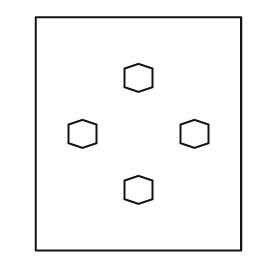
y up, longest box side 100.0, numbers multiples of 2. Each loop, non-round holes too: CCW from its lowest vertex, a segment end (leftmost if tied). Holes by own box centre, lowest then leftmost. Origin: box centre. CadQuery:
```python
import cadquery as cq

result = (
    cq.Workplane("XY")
    .moveTo(-44.0, -50.0)
    .lineTo(44.0, -50.0)
    .lineTo(44.0, 50.0)
    .lineTo(-44.0, 50.0)
    .close()
    .moveTo(0.0, -30.0)
    .lineTo(6.0, -28.0)
    .lineTo(6.0, -20.0)
    .lineTo(0.0, -18.0)
    .lineTo(-6.0, -20.0)
    .lineTo(-6.0, -28.0)
    .close()
    .moveTo(-24.0, -6.0)
    .lineTo(-18.0, -4.0)
    .lineTo(-18.0, 4.0)
    .lineTo(-24.0, 6.0)
    .lineTo(-30.0, 4.0)
    .lineTo(-30.0, -4.0)
    .close()
    .moveTo(24.0, -6.0)
    .lineTo(30.0, -4.0)
    .lineTo(30.0, 4.0)
    .lineTo(24.0, 6.0)
    .lineTo(18.0, 4.0)
    .lineTo(18.0, -4.0)
    .close()
    .moveTo(0.0, 18.0)
    .lineTo(6.0, 20.0)
    .lineTo(6.0, 28.0)
    .lineTo(0.0, 30.0)
    .lineTo(-6.0, 28.0)
    .lineTo(-6.0, 20.0)
    .close()
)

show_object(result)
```